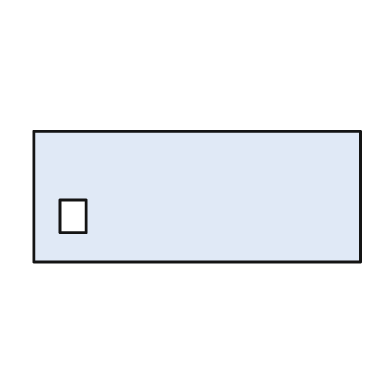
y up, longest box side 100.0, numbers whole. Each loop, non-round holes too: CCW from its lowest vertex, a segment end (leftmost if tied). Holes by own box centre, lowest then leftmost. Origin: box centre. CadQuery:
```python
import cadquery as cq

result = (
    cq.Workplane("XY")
    .moveTo(-50.0, -20.0)
    .lineTo(50.0, -20.0)
    .lineTo(50.0, 20.0)
    .lineTo(-50.0, 20.0)
    .close()
    .moveTo(-42.0, -11.0)
    .lineTo(-34.0, -11.0)
    .lineTo(-34.0, -1.0)
    .lineTo(-42.0, -1.0)
    .close()
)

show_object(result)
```